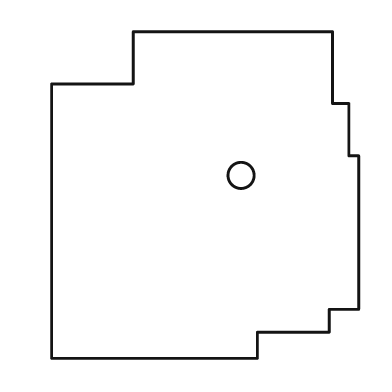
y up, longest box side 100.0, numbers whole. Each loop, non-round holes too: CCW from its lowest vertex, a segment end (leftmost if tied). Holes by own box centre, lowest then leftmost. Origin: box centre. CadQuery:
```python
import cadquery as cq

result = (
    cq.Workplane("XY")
    .moveTo(-47.0, -50.0)
    .lineTo(16.0, -50.0)
    .lineTo(16.0, -42.0)
    .lineTo(38.0, -42.0)
    .lineTo(38.0, -35.0)
    .lineTo(47.0, -35.0)
    .lineTo(47.0, 12.0)
    .lineTo(44.0, 12.0)
    .lineTo(44.0, 28.0)
    .lineTo(39.0, 28.0)
    .lineTo(39.0, 50.0)
    .lineTo(-22.0, 50.0)
    .lineTo(-22.0, 34.0)
    .lineTo(-47.0, 34.0)
    .close()
    .moveTo(11.0, 6.0)
    .circle(4.0)
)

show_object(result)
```